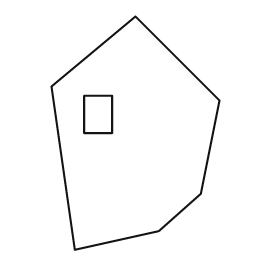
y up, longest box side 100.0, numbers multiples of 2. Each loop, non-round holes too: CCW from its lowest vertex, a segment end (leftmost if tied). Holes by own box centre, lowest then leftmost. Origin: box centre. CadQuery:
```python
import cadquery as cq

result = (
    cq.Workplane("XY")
    .moveTo(-26.0, -50.0)
    .lineTo(10.0, -42.0)
    .lineTo(28.0, -26.0)
    .lineTo(36.0, 14.0)
    .lineTo(0.0, 50.0)
    .lineTo(-36.0, 20.0)
    .close()
    .moveTo(-22.0, 0.0)
    .lineTo(-10.0, 0.0)
    .lineTo(-10.0, 16.0)
    .lineTo(-22.0, 16.0)
    .close()
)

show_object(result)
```